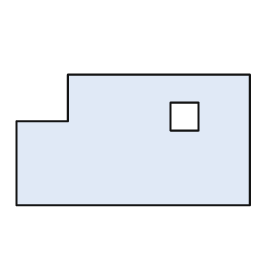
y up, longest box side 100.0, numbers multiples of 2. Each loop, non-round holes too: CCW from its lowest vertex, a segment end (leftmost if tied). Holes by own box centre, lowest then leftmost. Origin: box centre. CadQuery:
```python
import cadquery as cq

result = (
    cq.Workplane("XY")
    .moveTo(-50.0, -28.0)
    .lineTo(50.0, -28.0)
    .lineTo(50.0, 28.0)
    .lineTo(-28.0, 28.0)
    .lineTo(-28.0, 8.0)
    .lineTo(-50.0, 8.0)
    .close()
    .moveTo(16.0, 4.0)
    .lineTo(28.0, 4.0)
    .lineTo(28.0, 16.0)
    .lineTo(16.0, 16.0)
    .close()
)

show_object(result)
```